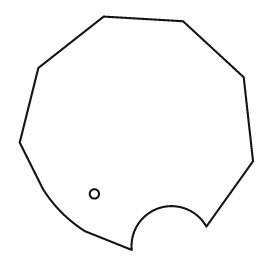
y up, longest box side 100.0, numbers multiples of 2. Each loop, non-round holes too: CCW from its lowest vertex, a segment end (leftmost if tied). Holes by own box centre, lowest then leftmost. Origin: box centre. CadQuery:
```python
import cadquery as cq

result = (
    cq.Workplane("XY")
    .moveTo(-2.0, -50.0)
    .threePointArc((10.0, -32.0), (30.0, -40.0))
    .lineTo(50.0, -12.0)
    .lineTo(46.0, 24.0)
    .lineTo(20.0, 48.0)
    .lineTo(-14.0, 50.0)
    .lineTo(-42.0, 28.0)
    .lineTo(-50.0, -4.0)
    .lineTo(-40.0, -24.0)
    .threePointArc((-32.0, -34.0), (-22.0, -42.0))
    .close()
    .moveTo(-18.0, -26.0)
    .circle(2.0)
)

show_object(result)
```